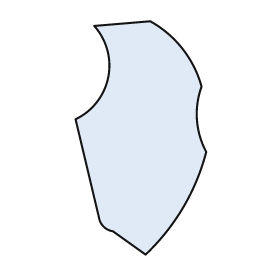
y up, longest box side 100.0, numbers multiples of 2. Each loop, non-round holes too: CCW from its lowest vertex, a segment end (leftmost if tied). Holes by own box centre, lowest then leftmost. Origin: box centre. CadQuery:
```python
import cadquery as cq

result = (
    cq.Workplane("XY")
    .moveTo(2.0, -50.0)
    .threePointArc((18.0, -30.0), (28.0, -6.0))
    .threePointArc((24.0, 8.0), (26.0, 22.0))
    .threePointArc((18.0, 38.0), (4.0, 50.0))
    .lineTo(-20.0, 48.0)
    .threePointArc((-14.0, 26.0), (-28.0, 8.0))
    .lineTo(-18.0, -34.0)
    .threePointArc((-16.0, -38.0), (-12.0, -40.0))
    .close()
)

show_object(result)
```